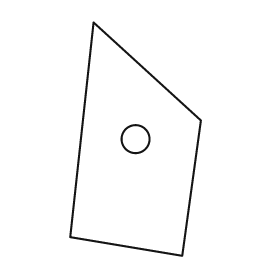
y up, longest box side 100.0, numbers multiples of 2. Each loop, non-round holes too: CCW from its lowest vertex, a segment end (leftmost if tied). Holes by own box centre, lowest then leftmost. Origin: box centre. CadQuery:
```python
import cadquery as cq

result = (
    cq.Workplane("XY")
    .moveTo(20.0, -50.0)
    .lineTo(28.0, 8.0)
    .lineTo(-18.0, 50.0)
    .lineTo(-28.0, -42.0)
    .close()
    .moveTo(0.0, 0.0)
    .circle(6.0)
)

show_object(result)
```